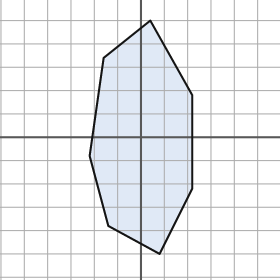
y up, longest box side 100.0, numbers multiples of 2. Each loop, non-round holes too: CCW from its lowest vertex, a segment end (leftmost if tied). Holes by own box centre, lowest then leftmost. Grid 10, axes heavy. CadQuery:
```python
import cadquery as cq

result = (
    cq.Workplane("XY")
    .moveTo(8.0, -50.0)
    .lineTo(22.0, -22.0)
    .lineTo(22.0, 18.0)
    .lineTo(4.0, 50.0)
    .lineTo(-16.0, 34.0)
    .lineTo(-22.0, -8.0)
    .lineTo(-14.0, -38.0)
    .close()
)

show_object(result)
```